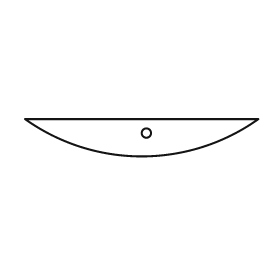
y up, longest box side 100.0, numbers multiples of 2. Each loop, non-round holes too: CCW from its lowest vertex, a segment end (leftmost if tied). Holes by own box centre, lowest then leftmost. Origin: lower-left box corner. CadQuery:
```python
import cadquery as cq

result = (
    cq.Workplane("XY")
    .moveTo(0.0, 16.0)
    .threePointArc((50.0, 0.0), (100.0, 16.0))
    .close()
    .moveTo(52.0, 10.0)
    .circle(2.0)
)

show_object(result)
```